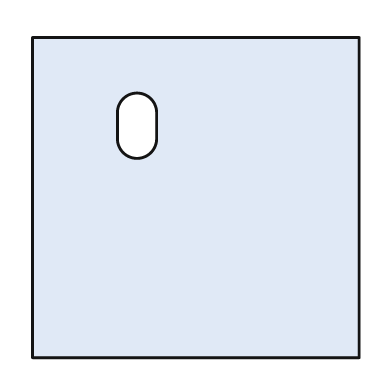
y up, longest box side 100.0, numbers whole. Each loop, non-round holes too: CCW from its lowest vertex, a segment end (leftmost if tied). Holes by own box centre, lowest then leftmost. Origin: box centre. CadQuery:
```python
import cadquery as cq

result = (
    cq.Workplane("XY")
    .moveTo(-50.0, -49.0)
    .lineTo(50.0, -49.0)
    .lineTo(50.0, 49.0)
    .lineTo(-50.0, 49.0)
    .close()
    .moveTo(-24.0, 18.0)
    .threePointArc((-18.0, 12.0), (-12.0, 18.0))
    .lineTo(-12.0, 26.0)
    .threePointArc((-18.0, 32.0), (-24.0, 26.0))
    .close()
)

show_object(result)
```